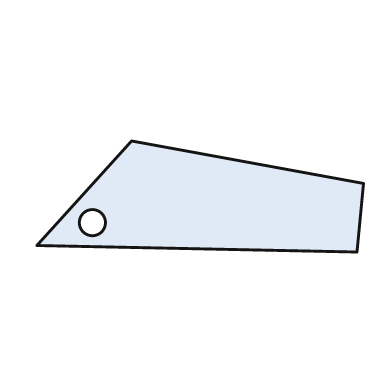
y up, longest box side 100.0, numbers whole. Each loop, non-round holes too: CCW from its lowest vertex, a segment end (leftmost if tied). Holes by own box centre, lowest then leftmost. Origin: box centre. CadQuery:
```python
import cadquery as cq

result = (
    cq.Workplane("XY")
    .moveTo(48.0, -17.0)
    .lineTo(50.0, 4.0)
    .lineTo(-21.0, 17.0)
    .lineTo(-50.0, -15.0)
    .close()
    .moveTo(-33.0, -8.0)
    .circle(4.0)
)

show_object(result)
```